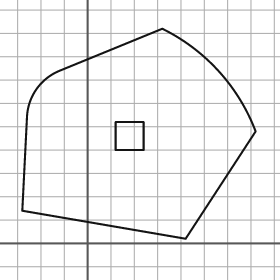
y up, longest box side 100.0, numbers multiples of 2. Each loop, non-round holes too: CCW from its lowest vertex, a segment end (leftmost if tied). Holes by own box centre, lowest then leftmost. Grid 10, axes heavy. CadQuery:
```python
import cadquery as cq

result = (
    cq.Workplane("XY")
    .moveTo(42.0, 2.0)
    .lineTo(72.0, 48.0)
    .threePointArc((56.0, 74.0), (32.0, 92.0))
    .lineTo(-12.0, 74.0)
    .threePointArc((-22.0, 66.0), (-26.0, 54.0))
    .lineTo(-28.0, 14.0)
    .close()
    .moveTo(12.0, 40.0)
    .lineTo(24.0, 40.0)
    .lineTo(24.0, 52.0)
    .lineTo(12.0, 52.0)
    .close()
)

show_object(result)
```